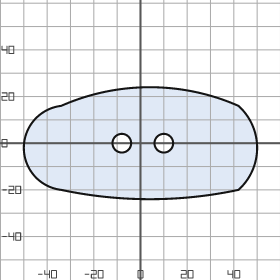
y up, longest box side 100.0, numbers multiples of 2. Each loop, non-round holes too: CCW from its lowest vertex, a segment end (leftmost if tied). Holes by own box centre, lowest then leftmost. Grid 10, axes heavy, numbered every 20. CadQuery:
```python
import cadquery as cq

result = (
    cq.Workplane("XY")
    .moveTo(-34.0, -20.0)
    .threePointArc((4.0, -24.0), (42.0, -20.0))
    .threePointArc((50.0, -2.0), (42.0, 16.0))
    .threePointArc((4.0, 24.0), (-34.0, 16.0))
    .threePointArc((-50.0, -2.0), (-34.0, -20.0))
    .close()
    .moveTo(-8.0, 0.0)
    .circle(4.0)
    .moveTo(10.0, 0.0)
    .circle(4.0)
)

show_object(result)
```